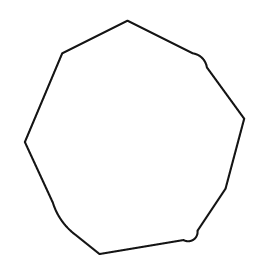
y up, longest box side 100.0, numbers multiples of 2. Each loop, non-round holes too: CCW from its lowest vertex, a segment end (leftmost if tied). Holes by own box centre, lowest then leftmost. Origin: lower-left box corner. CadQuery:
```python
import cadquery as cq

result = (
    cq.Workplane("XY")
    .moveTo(32.0, 0.0)
    .lineTo(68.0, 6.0)
    .threePointArc((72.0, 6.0), (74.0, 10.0))
    .lineTo(86.0, 28.0)
    .lineTo(94.0, 58.0)
    .lineTo(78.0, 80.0)
    .threePointArc((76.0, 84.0), (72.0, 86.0))
    .lineTo(44.0, 100.0)
    .lineTo(16.0, 86.0)
    .lineTo(0.0, 48.0)
    .lineTo(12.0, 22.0)
    .threePointArc((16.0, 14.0), (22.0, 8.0))
    .close()
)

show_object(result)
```